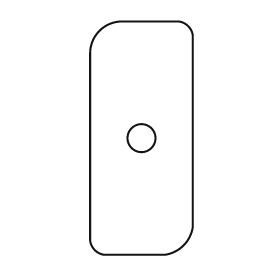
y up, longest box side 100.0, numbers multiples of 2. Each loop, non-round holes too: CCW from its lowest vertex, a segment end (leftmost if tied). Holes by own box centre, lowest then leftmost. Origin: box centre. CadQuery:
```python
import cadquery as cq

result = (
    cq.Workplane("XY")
    .moveTo(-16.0, -50.0)
    .lineTo(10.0, -50.0)
    .threePointArc((18.0, -46.0), (22.0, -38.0))
    .lineTo(22.0, 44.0)
    .threePointArc((20.0, 48.0), (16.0, 50.0))
    .lineTo(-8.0, 50.0)
    .threePointArc((-18.0, 46.0), (-22.0, 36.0))
    .lineTo(-22.0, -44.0)
    .threePointArc((-20.0, -48.0), (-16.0, -50.0))
    .close()
    .moveTo(0.0, 0.0)
    .circle(6.0)
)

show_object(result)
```